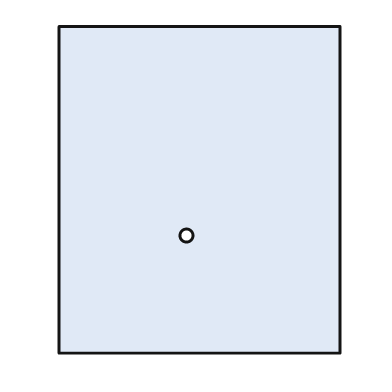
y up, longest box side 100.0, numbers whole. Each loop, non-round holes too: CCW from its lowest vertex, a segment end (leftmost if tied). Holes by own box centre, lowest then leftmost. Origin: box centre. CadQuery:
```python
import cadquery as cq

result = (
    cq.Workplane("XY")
    .moveTo(-43.0, -50.0)
    .lineTo(43.0, -50.0)
    .lineTo(43.0, 50.0)
    .lineTo(-43.0, 50.0)
    .close()
    .moveTo(-4.0, -14.0)
    .circle(2.0)
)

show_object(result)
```